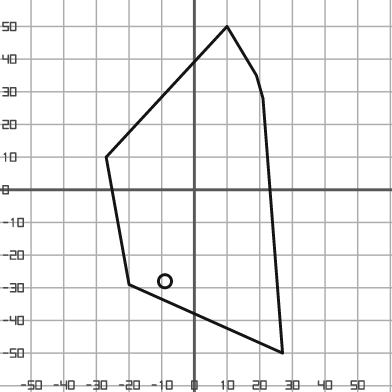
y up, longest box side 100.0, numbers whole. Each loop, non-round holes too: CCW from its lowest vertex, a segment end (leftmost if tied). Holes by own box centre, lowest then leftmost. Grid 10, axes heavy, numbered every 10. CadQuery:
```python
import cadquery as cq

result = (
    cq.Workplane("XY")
    .moveTo(27.0, -50.0)
    .lineTo(21.0, 28.0)
    .lineTo(19.0, 35.0)
    .lineTo(10.0, 50.0)
    .lineTo(-27.0, 10.0)
    .lineTo(-20.0, -29.0)
    .close()
    .moveTo(-9.0, -28.0)
    .circle(2.0)
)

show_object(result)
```